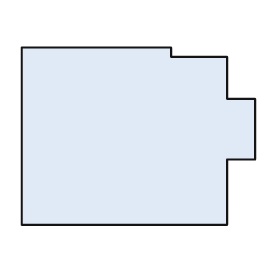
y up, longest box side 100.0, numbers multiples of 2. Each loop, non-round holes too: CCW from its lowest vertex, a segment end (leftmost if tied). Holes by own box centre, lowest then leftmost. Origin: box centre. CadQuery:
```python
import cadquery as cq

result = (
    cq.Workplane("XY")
    .moveTo(-50.0, -38.0)
    .lineTo(38.0, -38.0)
    .lineTo(38.0, -10.0)
    .lineTo(50.0, -10.0)
    .lineTo(50.0, 16.0)
    .lineTo(38.0, 16.0)
    .lineTo(38.0, 34.0)
    .lineTo(14.0, 34.0)
    .lineTo(14.0, 38.0)
    .lineTo(-50.0, 38.0)
    .close()
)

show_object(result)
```